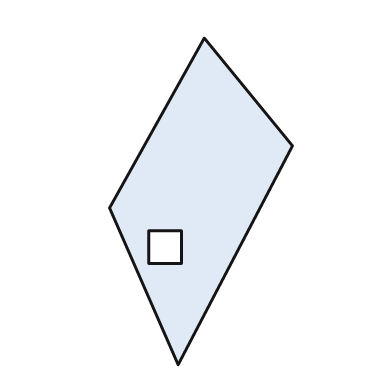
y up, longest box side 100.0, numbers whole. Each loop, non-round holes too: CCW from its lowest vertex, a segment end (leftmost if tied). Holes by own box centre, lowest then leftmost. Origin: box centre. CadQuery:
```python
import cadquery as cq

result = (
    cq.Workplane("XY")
    .moveTo(-7.0, -50.0)
    .lineTo(28.0, 17.0)
    .lineTo(1.0, 50.0)
    .lineTo(-28.0, -2.0)
    .close()
    .moveTo(-16.0, -19.0)
    .lineTo(-6.0, -19.0)
    .lineTo(-6.0, -9.0)
    .lineTo(-16.0, -9.0)
    .close()
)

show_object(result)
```